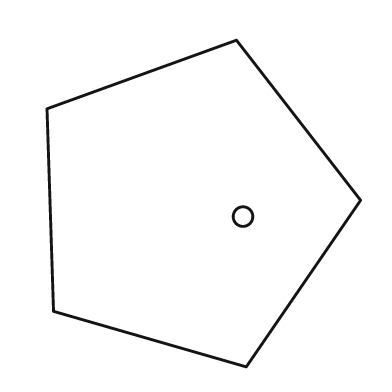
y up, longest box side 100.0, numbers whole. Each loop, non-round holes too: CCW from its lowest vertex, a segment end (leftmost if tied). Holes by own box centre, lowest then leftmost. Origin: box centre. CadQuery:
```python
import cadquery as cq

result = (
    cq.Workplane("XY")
    .moveTo(13.0, -50.0)
    .lineTo(48.0, 1.0)
    .lineTo(10.0, 50.0)
    .lineTo(-48.0, 29.0)
    .lineTo(-46.0, -33.0)
    .close()
    .moveTo(12.0, -4.0)
    .circle(3.0)
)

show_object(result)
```